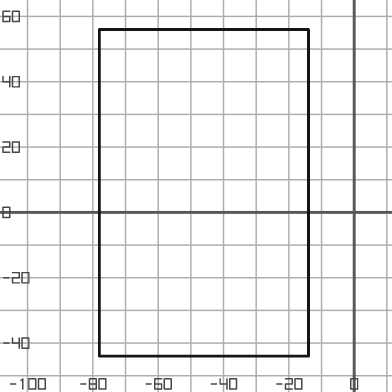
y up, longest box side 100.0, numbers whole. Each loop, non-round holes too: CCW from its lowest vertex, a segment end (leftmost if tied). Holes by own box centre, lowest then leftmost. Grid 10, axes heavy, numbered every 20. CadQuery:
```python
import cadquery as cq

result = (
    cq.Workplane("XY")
    .moveTo(-78.0, -44.0)
    .lineTo(-14.0, -44.0)
    .lineTo(-14.0, 56.0)
    .lineTo(-78.0, 56.0)
    .close()
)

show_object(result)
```